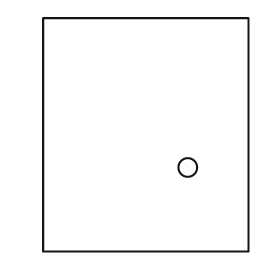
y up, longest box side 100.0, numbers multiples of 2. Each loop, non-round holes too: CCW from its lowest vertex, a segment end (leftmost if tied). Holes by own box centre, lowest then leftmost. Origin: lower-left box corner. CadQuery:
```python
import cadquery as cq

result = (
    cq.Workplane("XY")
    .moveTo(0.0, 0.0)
    .lineTo(88.0, 0.0)
    .lineTo(88.0, 100.0)
    .lineTo(0.0, 100.0)
    .close()
    .moveTo(62.0, 36.0)
    .circle(4.0)
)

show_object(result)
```